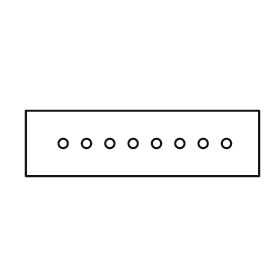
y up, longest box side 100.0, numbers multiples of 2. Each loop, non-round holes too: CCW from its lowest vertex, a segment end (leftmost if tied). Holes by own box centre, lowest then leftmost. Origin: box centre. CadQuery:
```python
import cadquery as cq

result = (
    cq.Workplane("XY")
    .moveTo(-50.0, -14.0)
    .lineTo(50.0, -14.0)
    .lineTo(50.0, 14.0)
    .lineTo(-50.0, 14.0)
    .close()
    .moveTo(-34.0, 0.0)
    .circle(2.0)
    .moveTo(-24.0, 0.0)
    .circle(2.0)
    .moveTo(-14.0, 0.0)
    .circle(2.0)
    .moveTo(-4.0, 0.0)
    .circle(2.0)
    .moveTo(6.0, 0.0)
    .circle(2.0)
    .moveTo(16.0, 0.0)
    .circle(2.0)
    .moveTo(26.0, 0.0)
    .circle(2.0)
    .moveTo(36.0, 0.0)
    .circle(2.0)
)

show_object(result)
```